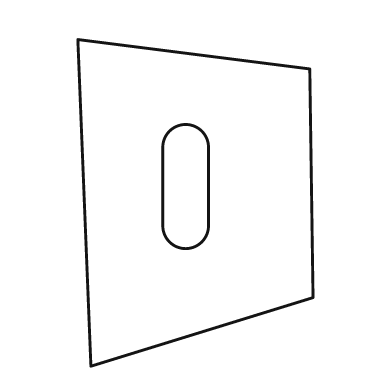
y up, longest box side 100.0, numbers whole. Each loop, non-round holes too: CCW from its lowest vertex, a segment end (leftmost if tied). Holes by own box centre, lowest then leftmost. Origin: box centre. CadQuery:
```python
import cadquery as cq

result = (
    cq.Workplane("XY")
    .moveTo(-32.0, -50.0)
    .lineTo(36.0, -29.0)
    .lineTo(35.0, 41.0)
    .lineTo(-36.0, 50.0)
    .close()
    .moveTo(-10.0, -7.0)
    .threePointArc((-3.0, -14.0), (4.0, -7.0))
    .lineTo(4.0, 17.0)
    .threePointArc((-3.0, 24.0), (-10.0, 17.0))
    .close()
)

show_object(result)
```